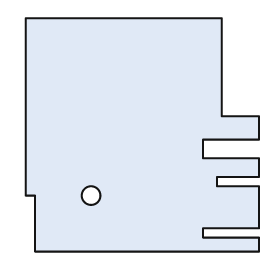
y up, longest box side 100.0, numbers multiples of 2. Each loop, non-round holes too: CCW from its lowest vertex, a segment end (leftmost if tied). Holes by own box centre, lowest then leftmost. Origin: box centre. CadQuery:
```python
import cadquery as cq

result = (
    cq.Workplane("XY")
    .moveTo(-46.0, -50.0)
    .lineTo(50.0, -50.0)
    .lineTo(50.0, -44.0)
    .lineTo(26.0, -44.0)
    .lineTo(26.0, -40.0)
    .lineTo(50.0, -40.0)
    .lineTo(50.0, -22.0)
    .lineTo(32.0, -22.0)
    .lineTo(32.0, -18.0)
    .lineTo(50.0, -18.0)
    .lineTo(50.0, -10.0)
    .lineTo(26.0, -10.0)
    .lineTo(26.0, -2.0)
    .lineTo(50.0, -2.0)
    .lineTo(50.0, 8.0)
    .lineTo(34.0, 8.0)
    .lineTo(34.0, 50.0)
    .lineTo(-50.0, 50.0)
    .lineTo(-50.0, -26.0)
    .lineTo(-46.0, -26.0)
    .close()
    .moveTo(-22.0, -26.0)
    .circle(4.0)
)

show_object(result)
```